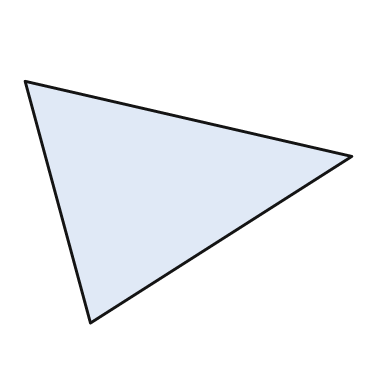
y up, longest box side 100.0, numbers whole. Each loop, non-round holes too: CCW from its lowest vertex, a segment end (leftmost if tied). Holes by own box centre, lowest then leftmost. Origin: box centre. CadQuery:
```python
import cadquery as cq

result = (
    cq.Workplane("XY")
    .moveTo(-30.0, -37.0)
    .lineTo(50.0, 14.0)
    .lineTo(-50.0, 37.0)
    .close()
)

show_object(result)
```